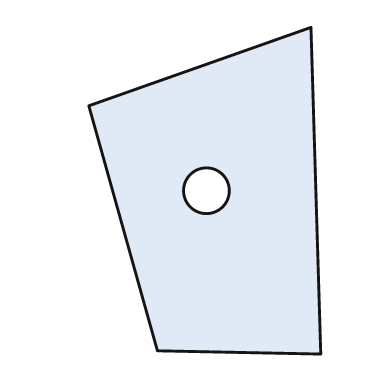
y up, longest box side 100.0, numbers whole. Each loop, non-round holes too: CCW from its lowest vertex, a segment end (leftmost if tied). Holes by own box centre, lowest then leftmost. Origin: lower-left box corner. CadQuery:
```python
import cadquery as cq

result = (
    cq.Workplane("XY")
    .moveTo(71.0, 0.0)
    .lineTo(68.0, 100.0)
    .lineTo(0.0, 76.0)
    .lineTo(21.0, 1.0)
    .close()
    .moveTo(36.0, 50.0)
    .circle(7.0)
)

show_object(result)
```